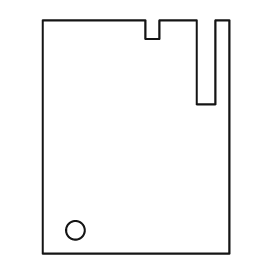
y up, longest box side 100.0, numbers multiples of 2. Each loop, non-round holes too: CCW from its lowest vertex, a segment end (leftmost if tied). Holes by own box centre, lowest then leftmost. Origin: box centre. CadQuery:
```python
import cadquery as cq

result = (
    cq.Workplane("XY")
    .moveTo(-40.0, -50.0)
    .lineTo(40.0, -50.0)
    .lineTo(40.0, 50.0)
    .lineTo(34.0, 50.0)
    .lineTo(34.0, 14.0)
    .lineTo(26.0, 14.0)
    .lineTo(26.0, 50.0)
    .lineTo(10.0, 50.0)
    .lineTo(10.0, 42.0)
    .lineTo(4.0, 42.0)
    .lineTo(4.0, 50.0)
    .lineTo(-40.0, 50.0)
    .close()
    .moveTo(-26.0, -40.0)
    .circle(4.0)
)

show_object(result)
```